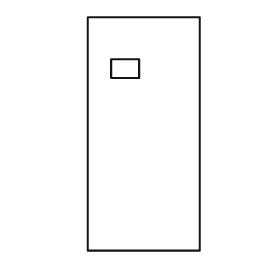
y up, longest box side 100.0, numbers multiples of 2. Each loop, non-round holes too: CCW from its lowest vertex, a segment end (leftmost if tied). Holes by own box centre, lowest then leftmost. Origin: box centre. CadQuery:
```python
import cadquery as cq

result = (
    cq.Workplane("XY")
    .moveTo(-24.0, -50.0)
    .lineTo(24.0, -50.0)
    .lineTo(24.0, 50.0)
    .lineTo(-24.0, 50.0)
    .close()
    .moveTo(-14.0, 24.0)
    .lineTo(-2.0, 24.0)
    .lineTo(-2.0, 32.0)
    .lineTo(-14.0, 32.0)
    .close()
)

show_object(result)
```